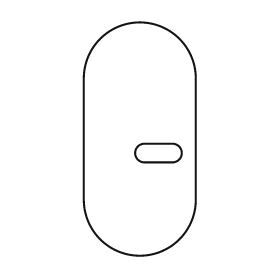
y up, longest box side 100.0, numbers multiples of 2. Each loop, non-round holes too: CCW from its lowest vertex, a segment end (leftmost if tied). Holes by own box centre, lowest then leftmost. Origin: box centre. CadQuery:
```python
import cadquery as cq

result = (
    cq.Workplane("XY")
    .moveTo(-24.0, -26.0)
    .threePointArc((0.0, -50.0), (24.0, -26.0))
    .lineTo(24.0, 26.0)
    .threePointArc((0.0, 50.0), (-24.0, 26.0))
    .close()
    .moveTo(2.0, -10.0)
    .lineTo(14.0, -10.0)
    .threePointArc((18.0, -6.0), (14.0, -2.0))
    .lineTo(2.0, -2.0)
    .threePointArc((-2.0, -6.0), (2.0, -10.0))
    .close()
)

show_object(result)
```